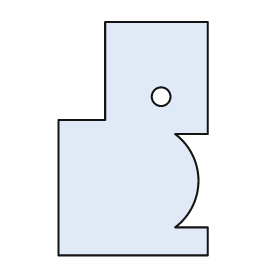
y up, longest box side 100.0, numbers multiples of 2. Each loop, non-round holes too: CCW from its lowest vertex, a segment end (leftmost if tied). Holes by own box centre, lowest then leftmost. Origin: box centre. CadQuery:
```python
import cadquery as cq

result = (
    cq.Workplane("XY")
    .moveTo(-32.0, -50.0)
    .lineTo(32.0, -50.0)
    .lineTo(32.0, -38.0)
    .lineTo(18.0, -38.0)
    .threePointArc((28.0, -18.0), (18.0, 2.0))
    .lineTo(32.0, 2.0)
    .lineTo(32.0, 50.0)
    .lineTo(-12.0, 50.0)
    .lineTo(-12.0, 8.0)
    .lineTo(-32.0, 8.0)
    .close()
    .moveTo(12.0, 18.0)
    .circle(4.0)
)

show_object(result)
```